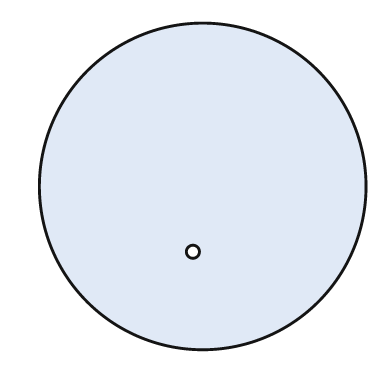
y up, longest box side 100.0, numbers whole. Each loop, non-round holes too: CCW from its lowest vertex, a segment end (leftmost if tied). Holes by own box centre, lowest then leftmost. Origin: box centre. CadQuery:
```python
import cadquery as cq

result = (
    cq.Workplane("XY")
    .moveTo(0.0, 0.0)
    .circle(50.0)
    .moveTo(-3.0, -20.0)
    .circle(2.0)
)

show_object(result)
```